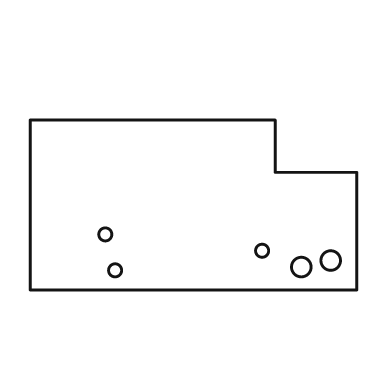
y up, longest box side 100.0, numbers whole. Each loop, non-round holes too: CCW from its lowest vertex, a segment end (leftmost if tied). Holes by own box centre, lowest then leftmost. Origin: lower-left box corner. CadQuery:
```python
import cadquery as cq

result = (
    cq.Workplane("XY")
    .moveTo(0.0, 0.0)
    .lineTo(100.0, 0.0)
    .lineTo(100.0, 36.0)
    .lineTo(75.0, 36.0)
    .lineTo(75.0, 52.0)
    .lineTo(0.0, 52.0)
    .close()
    .moveTo(26.0, 6.0)
    .circle(2.0)
    .moveTo(83.0, 7.0)
    .circle(3.0)
    .moveTo(92.0, 9.0)
    .circle(3.0)
    .moveTo(71.0, 12.0)
    .circle(2.0)
    .moveTo(23.0, 17.0)
    .circle(2.0)
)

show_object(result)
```